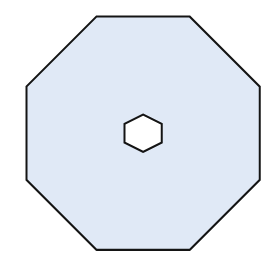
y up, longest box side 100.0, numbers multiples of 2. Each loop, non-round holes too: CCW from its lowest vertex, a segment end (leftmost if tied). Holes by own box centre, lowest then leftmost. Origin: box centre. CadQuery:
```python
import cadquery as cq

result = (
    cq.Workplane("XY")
    .moveTo(-20.0, -50.0)
    .lineTo(20.0, -50.0)
    .lineTo(50.0, -20.0)
    .lineTo(50.0, 20.0)
    .lineTo(20.0, 50.0)
    .lineTo(-20.0, 50.0)
    .lineTo(-50.0, 20.0)
    .lineTo(-50.0, -20.0)
    .close()
    .moveTo(0.0, -8.0)
    .lineTo(8.0, -4.0)
    .lineTo(8.0, 4.0)
    .lineTo(0.0, 8.0)
    .lineTo(-8.0, 4.0)
    .lineTo(-8.0, -4.0)
    .close()
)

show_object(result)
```